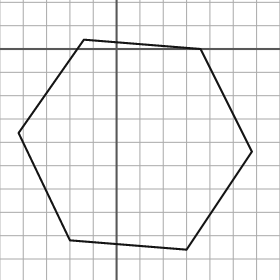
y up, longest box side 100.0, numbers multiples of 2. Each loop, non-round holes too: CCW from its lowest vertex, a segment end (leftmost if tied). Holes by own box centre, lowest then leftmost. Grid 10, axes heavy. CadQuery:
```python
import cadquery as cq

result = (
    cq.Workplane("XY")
    .moveTo(30.0, -86.0)
    .lineTo(58.0, -44.0)
    .lineTo(36.0, 0.0)
    .lineTo(-14.0, 4.0)
    .lineTo(-42.0, -36.0)
    .lineTo(-20.0, -82.0)
    .close()
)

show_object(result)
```